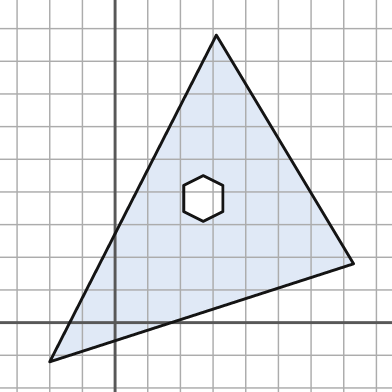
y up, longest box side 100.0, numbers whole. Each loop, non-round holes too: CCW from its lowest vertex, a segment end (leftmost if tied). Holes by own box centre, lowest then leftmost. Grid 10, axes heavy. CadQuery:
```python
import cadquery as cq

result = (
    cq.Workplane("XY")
    .moveTo(-20.0, -12.0)
    .lineTo(73.0, 18.0)
    .lineTo(31.0, 88.0)
    .close()
    .moveTo(27.0, 31.0)
    .lineTo(33.0, 34.0)
    .lineTo(33.0, 42.0)
    .lineTo(27.0, 45.0)
    .lineTo(21.0, 42.0)
    .lineTo(21.0, 34.0)
    .close()
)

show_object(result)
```